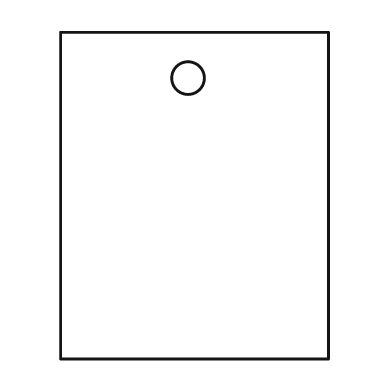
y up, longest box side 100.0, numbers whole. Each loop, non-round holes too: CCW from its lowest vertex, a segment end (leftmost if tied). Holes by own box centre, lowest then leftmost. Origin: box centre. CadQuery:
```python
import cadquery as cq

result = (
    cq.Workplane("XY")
    .moveTo(-41.0, -50.0)
    .lineTo(41.0, -50.0)
    .lineTo(41.0, 50.0)
    .lineTo(-41.0, 50.0)
    .close()
    .moveTo(-2.0, 36.0)
    .circle(5.0)
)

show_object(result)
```